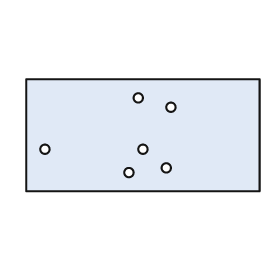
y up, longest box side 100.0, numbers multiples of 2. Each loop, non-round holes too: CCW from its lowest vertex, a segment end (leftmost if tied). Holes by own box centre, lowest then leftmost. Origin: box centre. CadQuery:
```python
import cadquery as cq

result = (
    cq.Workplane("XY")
    .moveTo(-50.0, -24.0)
    .lineTo(50.0, -24.0)
    .lineTo(50.0, 24.0)
    .lineTo(-50.0, 24.0)
    .close()
    .moveTo(-6.0, -16.0)
    .circle(2.0)
    .moveTo(10.0, -14.0)
    .circle(2.0)
    .moveTo(-42.0, -6.0)
    .circle(2.0)
    .moveTo(0.0, -6.0)
    .circle(2.0)
    .moveTo(12.0, 12.0)
    .circle(2.0)
    .moveTo(-2.0, 16.0)
    .circle(2.0)
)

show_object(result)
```